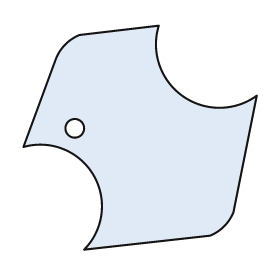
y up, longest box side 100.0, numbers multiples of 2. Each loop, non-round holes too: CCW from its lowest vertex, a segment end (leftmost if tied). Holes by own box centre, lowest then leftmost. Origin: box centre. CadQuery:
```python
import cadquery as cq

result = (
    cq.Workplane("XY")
    .moveTo(-24.0, -48.0)
    .lineTo(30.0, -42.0)
    .threePointArc((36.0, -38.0), (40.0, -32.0))
    .lineTo(50.0, 18.0)
    .threePointArc((18.0, 18.0), (8.0, 48.0))
    .lineTo(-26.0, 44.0)
    .threePointArc((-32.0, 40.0), (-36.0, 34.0))
    .lineTo(-50.0, -4.0)
    .threePointArc((-20.0, -16.0), (-24.0, -48.0))
    .close()
    .moveTo(-28.0, 4.0)
    .circle(4.0)
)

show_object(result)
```